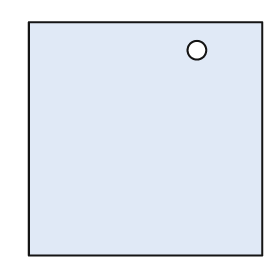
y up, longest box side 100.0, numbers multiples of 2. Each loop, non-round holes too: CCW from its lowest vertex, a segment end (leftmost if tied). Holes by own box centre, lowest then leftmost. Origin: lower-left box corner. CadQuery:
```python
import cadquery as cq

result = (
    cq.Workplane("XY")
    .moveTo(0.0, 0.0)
    .lineTo(100.0, 0.0)
    .lineTo(100.0, 100.0)
    .lineTo(0.0, 100.0)
    .close()
    .moveTo(72.0, 88.0)
    .circle(4.0)
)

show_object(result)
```